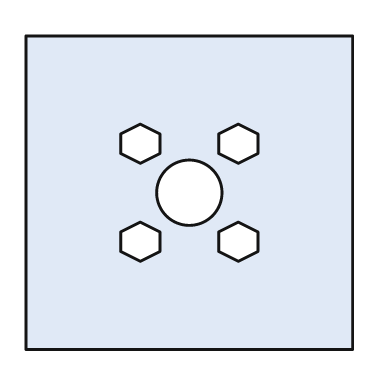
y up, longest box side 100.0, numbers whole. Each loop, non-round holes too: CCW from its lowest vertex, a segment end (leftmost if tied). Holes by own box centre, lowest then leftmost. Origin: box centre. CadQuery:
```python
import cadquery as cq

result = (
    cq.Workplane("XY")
    .moveTo(-50.0, -48.0)
    .lineTo(50.0, -48.0)
    .lineTo(50.0, 48.0)
    .lineTo(-50.0, 48.0)
    .close()
    .moveTo(-15.0, -21.0)
    .lineTo(-9.0, -18.0)
    .lineTo(-9.0, -12.0)
    .lineTo(-15.0, -9.0)
    .lineTo(-21.0, -12.0)
    .lineTo(-21.0, -18.0)
    .close()
    .moveTo(15.0, -21.0)
    .lineTo(21.0, -18.0)
    .lineTo(21.0, -12.0)
    .lineTo(15.0, -9.0)
    .lineTo(9.0, -12.0)
    .lineTo(9.0, -18.0)
    .close()
    .moveTo(0.0, 0.0)
    .circle(10.0)
    .moveTo(-15.0, 9.0)
    .lineTo(-9.0, 12.0)
    .lineTo(-9.0, 18.0)
    .lineTo(-15.0, 21.0)
    .lineTo(-21.0, 18.0)
    .lineTo(-21.0, 12.0)
    .close()
    .moveTo(15.0, 9.0)
    .lineTo(21.0, 12.0)
    .lineTo(21.0, 18.0)
    .lineTo(15.0, 21.0)
    .lineTo(9.0, 18.0)
    .lineTo(9.0, 12.0)
    .close()
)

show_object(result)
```